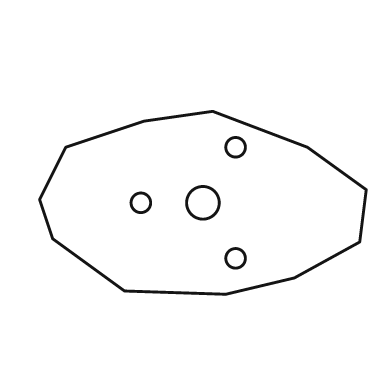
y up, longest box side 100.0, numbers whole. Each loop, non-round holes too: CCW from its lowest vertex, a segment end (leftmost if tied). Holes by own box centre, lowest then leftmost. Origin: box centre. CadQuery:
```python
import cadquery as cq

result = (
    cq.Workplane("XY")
    .moveTo(7.0, -28.0)
    .lineTo(28.0, -23.0)
    .lineTo(48.0, -12.0)
    .lineTo(50.0, 4.0)
    .lineTo(32.0, 17.0)
    .lineTo(3.0, 28.0)
    .lineTo(-18.0, 25.0)
    .lineTo(-42.0, 17.0)
    .lineTo(-50.0, 1.0)
    .lineTo(-46.0, -11.0)
    .lineTo(-24.0, -27.0)
    .close()
    .moveTo(10.0, -17.0)
    .circle(3.0)
    .moveTo(-19.0, 0.0)
    .circle(3.0)
    .moveTo(0.0, 0.0)
    .circle(5.0)
    .moveTo(10.0, 17.0)
    .circle(3.0)
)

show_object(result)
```